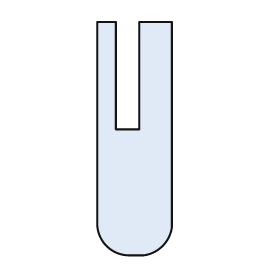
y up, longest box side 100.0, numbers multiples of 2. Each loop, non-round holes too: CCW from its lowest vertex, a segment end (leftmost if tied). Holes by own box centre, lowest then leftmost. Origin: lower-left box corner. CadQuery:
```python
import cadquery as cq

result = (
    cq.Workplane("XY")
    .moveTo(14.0, 0.0)
    .lineTo(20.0, 0.0)
    .threePointArc((28.0, 4.0), (32.0, 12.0))
    .lineTo(32.0, 100.0)
    .lineTo(18.0, 100.0)
    .lineTo(18.0, 54.0)
    .lineTo(8.0, 54.0)
    .lineTo(8.0, 100.0)
    .lineTo(0.0, 100.0)
    .lineTo(0.0, 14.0)
    .threePointArc((4.0, 4.0), (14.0, 0.0))
    .close()
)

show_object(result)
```